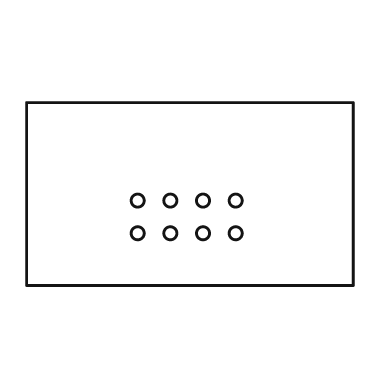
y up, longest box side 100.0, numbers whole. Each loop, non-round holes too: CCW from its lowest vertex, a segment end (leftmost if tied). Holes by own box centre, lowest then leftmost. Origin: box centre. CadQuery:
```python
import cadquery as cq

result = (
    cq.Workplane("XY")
    .moveTo(-50.0, -28.0)
    .lineTo(50.0, -28.0)
    .lineTo(50.0, 28.0)
    .lineTo(-50.0, 28.0)
    .close()
    .moveTo(-16.0, -12.0)
    .circle(2.0)
    .moveTo(-6.0, -12.0)
    .circle(2.0)
    .moveTo(4.0, -12.0)
    .circle(2.0)
    .moveTo(14.0, -12.0)
    .circle(2.0)
    .moveTo(-16.0, -2.0)
    .circle(2.0)
    .moveTo(-6.0, -2.0)
    .circle(2.0)
    .moveTo(4.0, -2.0)
    .circle(2.0)
    .moveTo(14.0, -2.0)
    .circle(2.0)
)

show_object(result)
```